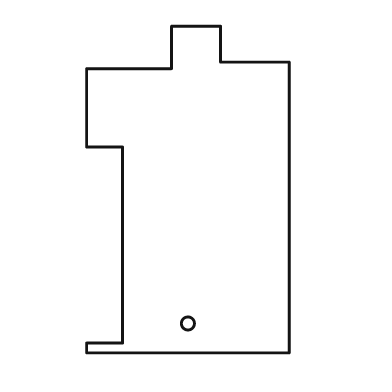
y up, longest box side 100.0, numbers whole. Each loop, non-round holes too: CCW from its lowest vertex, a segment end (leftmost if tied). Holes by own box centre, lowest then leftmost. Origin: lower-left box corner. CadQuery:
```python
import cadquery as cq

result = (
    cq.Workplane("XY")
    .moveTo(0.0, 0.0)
    .lineTo(62.0, 0.0)
    .lineTo(62.0, 89.0)
    .lineTo(41.0, 89.0)
    .lineTo(41.0, 100.0)
    .lineTo(26.0, 100.0)
    .lineTo(26.0, 87.0)
    .lineTo(0.0, 87.0)
    .lineTo(0.0, 63.0)
    .lineTo(11.0, 63.0)
    .lineTo(11.0, 3.0)
    .lineTo(0.0, 3.0)
    .close()
    .moveTo(31.0, 9.0)
    .circle(2.0)
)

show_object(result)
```